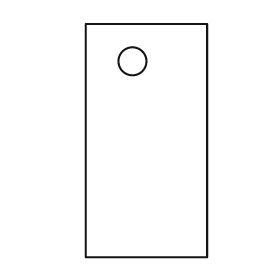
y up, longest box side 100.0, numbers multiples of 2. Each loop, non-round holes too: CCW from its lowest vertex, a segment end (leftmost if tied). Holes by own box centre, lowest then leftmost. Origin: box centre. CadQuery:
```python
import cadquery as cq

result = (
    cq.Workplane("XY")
    .moveTo(-26.0, -50.0)
    .lineTo(26.0, -50.0)
    .lineTo(26.0, 50.0)
    .lineTo(-26.0, 50.0)
    .close()
    .moveTo(-6.0, 34.0)
    .circle(6.0)
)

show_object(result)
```